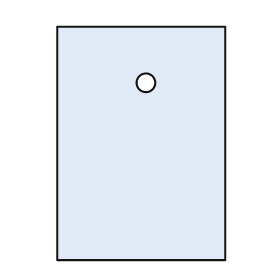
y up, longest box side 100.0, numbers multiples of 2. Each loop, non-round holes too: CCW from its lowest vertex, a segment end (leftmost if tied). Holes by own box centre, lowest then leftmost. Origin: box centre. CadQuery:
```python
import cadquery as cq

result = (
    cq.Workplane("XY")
    .moveTo(-36.0, -50.0)
    .lineTo(36.0, -50.0)
    .lineTo(36.0, 50.0)
    .lineTo(-36.0, 50.0)
    .close()
    .moveTo(2.0, 26.0)
    .circle(4.0)
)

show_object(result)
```